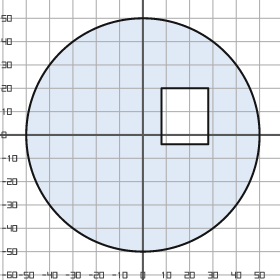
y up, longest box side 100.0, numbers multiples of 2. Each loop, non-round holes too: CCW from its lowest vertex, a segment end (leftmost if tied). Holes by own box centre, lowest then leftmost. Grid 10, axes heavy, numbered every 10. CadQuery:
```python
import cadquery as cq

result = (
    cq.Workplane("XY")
    .moveTo(0.0, 0.0)
    .circle(50.0)
    .moveTo(8.0, -4.0)
    .lineTo(28.0, -4.0)
    .lineTo(28.0, 20.0)
    .lineTo(8.0, 20.0)
    .close()
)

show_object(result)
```